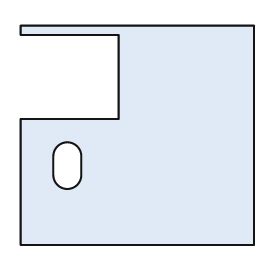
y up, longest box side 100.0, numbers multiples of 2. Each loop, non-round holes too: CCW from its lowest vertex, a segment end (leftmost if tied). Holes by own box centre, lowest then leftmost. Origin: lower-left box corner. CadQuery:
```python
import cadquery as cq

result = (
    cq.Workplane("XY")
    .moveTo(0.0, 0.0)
    .lineTo(100.0, 0.0)
    .lineTo(100.0, 94.0)
    .lineTo(0.0, 94.0)
    .lineTo(0.0, 90.0)
    .lineTo(42.0, 90.0)
    .lineTo(42.0, 54.0)
    .lineTo(0.0, 54.0)
    .close()
    .moveTo(14.0, 30.0)
    .threePointArc((20.0, 24.0), (26.0, 30.0))
    .lineTo(26.0, 38.0)
    .threePointArc((20.0, 44.0), (14.0, 38.0))
    .close()
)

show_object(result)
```